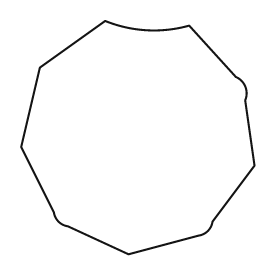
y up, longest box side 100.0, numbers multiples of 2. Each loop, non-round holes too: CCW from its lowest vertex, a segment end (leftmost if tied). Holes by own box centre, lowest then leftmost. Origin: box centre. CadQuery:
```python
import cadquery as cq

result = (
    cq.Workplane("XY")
    .moveTo(-4.0, -50.0)
    .lineTo(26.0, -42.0)
    .threePointArc((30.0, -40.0), (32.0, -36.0))
    .lineTo(50.0, -12.0)
    .lineTo(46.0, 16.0)
    .threePointArc((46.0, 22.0), (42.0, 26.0))
    .lineTo(22.0, 48.0)
    .threePointArc((4.0, 46.0), (-14.0, 50.0))
    .lineTo(-42.0, 30.0)
    .lineTo(-50.0, -4.0)
    .lineTo(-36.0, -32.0)
    .threePointArc((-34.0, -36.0), (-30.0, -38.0))
    .close()
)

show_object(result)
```